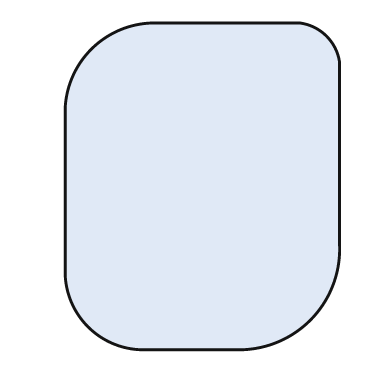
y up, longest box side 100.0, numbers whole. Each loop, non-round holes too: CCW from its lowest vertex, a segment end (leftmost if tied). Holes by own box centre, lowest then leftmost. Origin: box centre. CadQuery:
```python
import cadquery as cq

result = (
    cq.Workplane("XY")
    .moveTo(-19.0, -50.0)
    .lineTo(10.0, -50.0)
    .threePointArc((33.0, -41.0), (42.0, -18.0))
    .lineTo(42.0, 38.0)
    .threePointArc((38.0, 46.0), (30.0, 50.0))
    .lineTo(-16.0, 50.0)
    .threePointArc((-34.0, 42.0), (-42.0, 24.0))
    .lineTo(-42.0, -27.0)
    .threePointArc((-35.0, -43.0), (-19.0, -50.0))
    .close()
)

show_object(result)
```